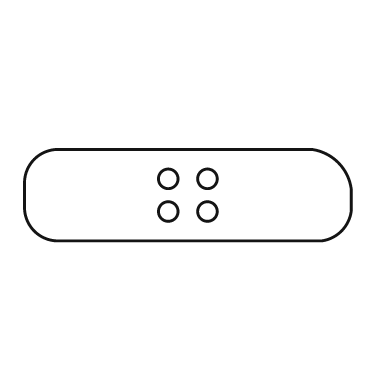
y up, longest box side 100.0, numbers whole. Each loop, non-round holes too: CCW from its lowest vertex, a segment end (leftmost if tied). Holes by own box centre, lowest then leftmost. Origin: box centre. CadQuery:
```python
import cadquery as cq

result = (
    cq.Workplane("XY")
    .moveTo(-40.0, -14.0)
    .lineTo(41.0, -14.0)
    .threePointArc((47.0, -11.0), (50.0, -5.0))
    .lineTo(50.0, 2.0)
    .threePointArc((46.0, 10.0), (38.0, 14.0))
    .lineTo(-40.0, 14.0)
    .threePointArc((-47.0, 11.0), (-50.0, 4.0))
    .lineTo(-50.0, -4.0)
    .threePointArc((-47.0, -11.0), (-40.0, -14.0))
    .close()
    .moveTo(-6.0, -5.0)
    .circle(3.0)
    .moveTo(6.0, -5.0)
    .circle(3.0)
    .moveTo(-6.0, 5.0)
    .circle(3.0)
    .moveTo(6.0, 5.0)
    .circle(3.0)
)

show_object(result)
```